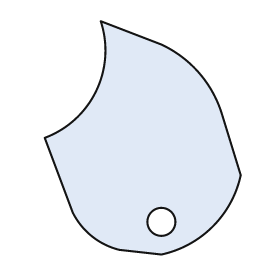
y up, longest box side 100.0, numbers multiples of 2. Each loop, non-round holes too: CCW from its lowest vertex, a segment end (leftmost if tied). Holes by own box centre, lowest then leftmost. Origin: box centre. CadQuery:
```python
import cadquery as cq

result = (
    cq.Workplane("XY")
    .moveTo(8.0, -50.0)
    .threePointArc((30.0, -38.0), (42.0, -16.0))
    .lineTo(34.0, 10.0)
    .threePointArc((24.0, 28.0), (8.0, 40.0))
    .lineTo(-18.0, 50.0)
    .threePointArc((-20.0, 20.0), (-42.0, 0.0))
    .lineTo(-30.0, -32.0)
    .threePointArc((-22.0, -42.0), (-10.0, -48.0))
    .close()
    .moveTo(8.0, -36.0)
    .circle(6.0)
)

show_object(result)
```